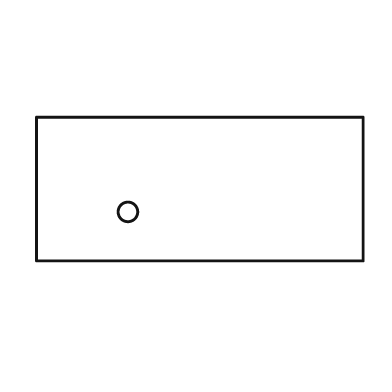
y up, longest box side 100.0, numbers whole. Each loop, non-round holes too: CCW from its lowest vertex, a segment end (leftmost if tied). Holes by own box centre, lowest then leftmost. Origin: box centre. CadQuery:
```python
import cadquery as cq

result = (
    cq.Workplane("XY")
    .moveTo(-50.0, -22.0)
    .lineTo(50.0, -22.0)
    .lineTo(50.0, 22.0)
    .lineTo(-50.0, 22.0)
    .close()
    .moveTo(-22.0, -7.0)
    .circle(3.0)
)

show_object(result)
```